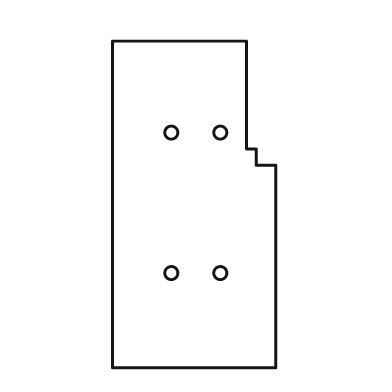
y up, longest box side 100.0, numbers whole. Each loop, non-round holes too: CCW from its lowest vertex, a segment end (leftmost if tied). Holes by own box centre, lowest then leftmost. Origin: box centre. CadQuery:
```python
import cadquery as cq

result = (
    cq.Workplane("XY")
    .moveTo(-25.0, -50.0)
    .lineTo(25.0, -50.0)
    .lineTo(25.0, 12.0)
    .lineTo(19.0, 12.0)
    .lineTo(19.0, 17.0)
    .lineTo(16.0, 17.0)
    .lineTo(16.0, 50.0)
    .lineTo(-25.0, 50.0)
    .close()
    .moveTo(-7.0, -21.0)
    .circle(2.0)
    .moveTo(8.0, -21.0)
    .circle(2.0)
    .moveTo(-7.0, 22.0)
    .circle(2.0)
    .moveTo(8.0, 22.0)
    .circle(2.0)
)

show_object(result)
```